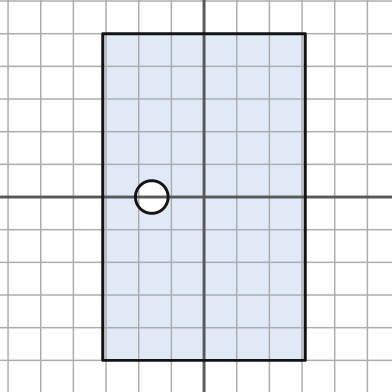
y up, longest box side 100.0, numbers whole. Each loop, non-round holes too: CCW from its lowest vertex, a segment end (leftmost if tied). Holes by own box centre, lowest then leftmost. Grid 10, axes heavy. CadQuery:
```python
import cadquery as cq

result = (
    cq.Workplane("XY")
    .moveTo(-31.0, -50.0)
    .lineTo(31.0, -50.0)
    .lineTo(31.0, 50.0)
    .lineTo(-31.0, 50.0)
    .close()
    .moveTo(-16.0, 0.0)
    .circle(5.0)
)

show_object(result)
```